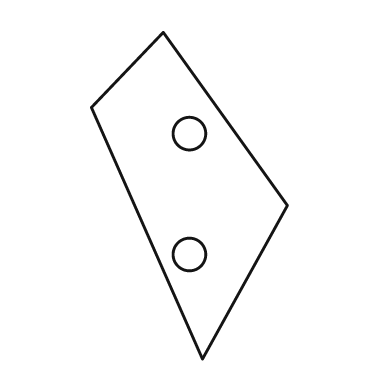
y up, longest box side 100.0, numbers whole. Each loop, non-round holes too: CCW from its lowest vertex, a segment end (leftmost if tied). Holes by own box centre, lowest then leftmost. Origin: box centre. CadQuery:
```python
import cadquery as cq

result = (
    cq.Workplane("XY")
    .moveTo(4.0, -50.0)
    .lineTo(30.0, -3.0)
    .lineTo(-8.0, 50.0)
    .lineTo(-30.0, 27.0)
    .close()
    .moveTo(0.0, -18.0)
    .circle(5.0)
    .moveTo(0.0, 19.0)
    .circle(5.0)
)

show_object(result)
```